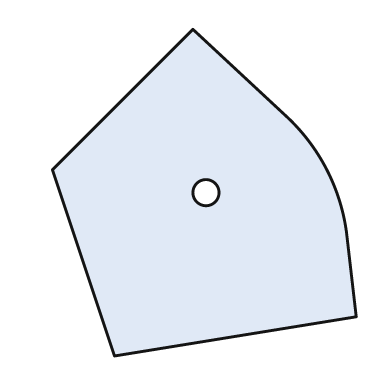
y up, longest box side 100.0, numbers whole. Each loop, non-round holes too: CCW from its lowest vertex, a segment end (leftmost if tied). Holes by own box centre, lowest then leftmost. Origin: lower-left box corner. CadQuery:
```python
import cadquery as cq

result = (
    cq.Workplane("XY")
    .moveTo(19.0, 0.0)
    .lineTo(93.0, 12.0)
    .lineTo(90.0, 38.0)
    .threePointArc((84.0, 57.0), (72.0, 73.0))
    .lineTo(43.0, 100.0)
    .lineTo(0.0, 57.0)
    .close()
    .moveTo(47.0, 50.0)
    .circle(4.0)
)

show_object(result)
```